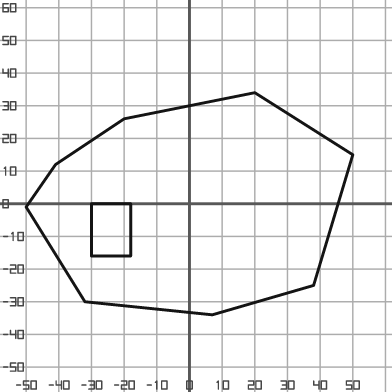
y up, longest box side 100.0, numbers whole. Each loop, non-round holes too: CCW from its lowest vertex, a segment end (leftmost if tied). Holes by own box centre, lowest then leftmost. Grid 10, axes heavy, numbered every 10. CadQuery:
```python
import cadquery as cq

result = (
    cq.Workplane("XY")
    .moveTo(7.0, -34.0)
    .lineTo(38.0, -25.0)
    .lineTo(50.0, 15.0)
    .lineTo(20.0, 34.0)
    .lineTo(-20.0, 26.0)
    .lineTo(-41.0, 12.0)
    .lineTo(-50.0, -1.0)
    .lineTo(-32.0, -30.0)
    .close()
    .moveTo(-30.0, -16.0)
    .lineTo(-18.0, -16.0)
    .lineTo(-18.0, 0.0)
    .lineTo(-30.0, 0.0)
    .close()
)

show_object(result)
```